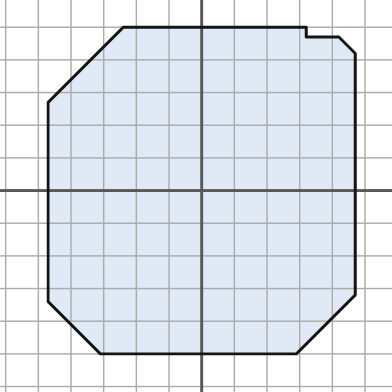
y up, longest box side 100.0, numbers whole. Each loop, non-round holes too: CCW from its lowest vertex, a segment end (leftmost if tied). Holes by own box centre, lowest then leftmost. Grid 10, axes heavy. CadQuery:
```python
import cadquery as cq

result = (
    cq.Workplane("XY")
    .moveTo(-31.0, -50.0)
    .lineTo(29.0, -50.0)
    .lineTo(47.0, -32.0)
    .lineTo(47.0, 42.0)
    .lineTo(42.0, 47.0)
    .lineTo(32.0, 47.0)
    .lineTo(32.0, 50.0)
    .lineTo(-24.0, 50.0)
    .lineTo(-47.0, 27.0)
    .lineTo(-47.0, -34.0)
    .close()
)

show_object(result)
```